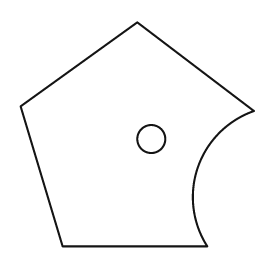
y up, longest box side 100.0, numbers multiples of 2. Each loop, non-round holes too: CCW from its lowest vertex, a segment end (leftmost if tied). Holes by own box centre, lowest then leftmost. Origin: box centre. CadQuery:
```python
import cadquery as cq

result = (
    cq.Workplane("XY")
    .moveTo(-32.0, -48.0)
    .lineTo(30.0, -48.0)
    .threePointArc((26.0, -14.0), (50.0, 10.0))
    .lineTo(0.0, 48.0)
    .lineTo(-50.0, 12.0)
    .close()
    .moveTo(6.0, -2.0)
    .circle(6.0)
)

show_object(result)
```